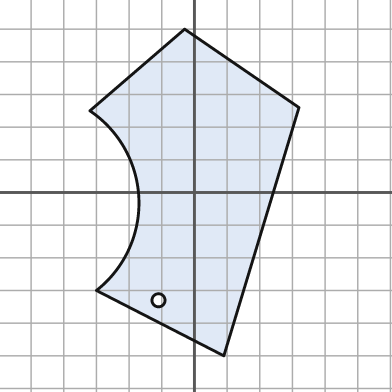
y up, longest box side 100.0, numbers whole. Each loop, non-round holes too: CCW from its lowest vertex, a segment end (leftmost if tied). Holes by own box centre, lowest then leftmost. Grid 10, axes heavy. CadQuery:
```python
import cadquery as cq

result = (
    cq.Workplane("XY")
    .moveTo(9.0, -50.0)
    .lineTo(32.0, 26.0)
    .lineTo(-3.0, 50.0)
    .lineTo(-32.0, 25.0)
    .threePointArc((-17.0, -2.0), (-30.0, -30.0))
    .close()
    .moveTo(-11.0, -33.0)
    .circle(2.0)
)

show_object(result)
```